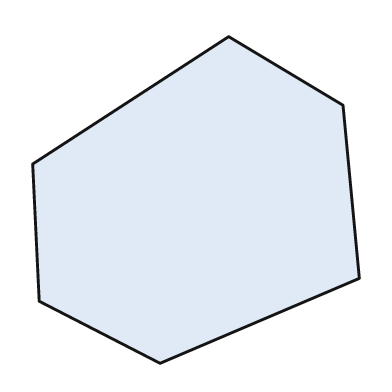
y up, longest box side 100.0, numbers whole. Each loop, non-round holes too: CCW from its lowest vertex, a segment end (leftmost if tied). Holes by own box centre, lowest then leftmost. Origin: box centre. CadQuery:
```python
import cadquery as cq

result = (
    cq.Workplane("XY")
    .moveTo(-11.0, -50.0)
    .lineTo(50.0, -24.0)
    .lineTo(45.0, 29.0)
    .lineTo(10.0, 50.0)
    .lineTo(-50.0, 11.0)
    .lineTo(-48.0, -31.0)
    .close()
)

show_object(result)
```